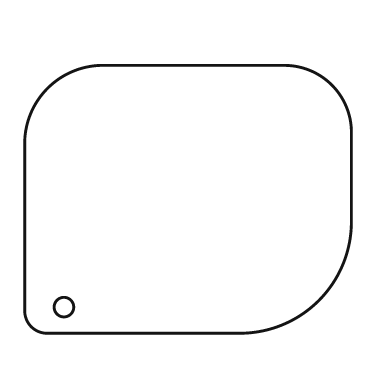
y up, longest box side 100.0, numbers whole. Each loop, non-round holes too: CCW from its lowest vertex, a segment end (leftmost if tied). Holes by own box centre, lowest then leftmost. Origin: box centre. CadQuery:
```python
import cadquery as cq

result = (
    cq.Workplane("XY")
    .moveTo(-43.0, -41.0)
    .lineTo(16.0, -41.0)
    .threePointArc((40.0, -31.0), (50.0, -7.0))
    .lineTo(50.0, 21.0)
    .threePointArc((44.0, 35.0), (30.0, 41.0))
    .lineTo(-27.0, 41.0)
    .threePointArc((-43.0, 34.0), (-50.0, 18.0))
    .lineTo(-50.0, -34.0)
    .threePointArc((-48.0, -39.0), (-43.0, -41.0))
    .close()
    .moveTo(-38.0, -33.0)
    .circle(3.0)
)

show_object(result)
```